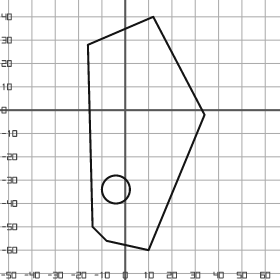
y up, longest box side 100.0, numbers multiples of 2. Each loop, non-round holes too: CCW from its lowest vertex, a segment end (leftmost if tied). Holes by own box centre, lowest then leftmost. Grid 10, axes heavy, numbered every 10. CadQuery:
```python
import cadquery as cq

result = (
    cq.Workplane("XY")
    .moveTo(10.0, -60.0)
    .lineTo(34.0, -2.0)
    .lineTo(12.0, 40.0)
    .lineTo(-16.0, 28.0)
    .lineTo(-14.0, -50.0)
    .lineTo(-8.0, -56.0)
    .close()
    .moveTo(-4.0, -34.0)
    .circle(6.0)
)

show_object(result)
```